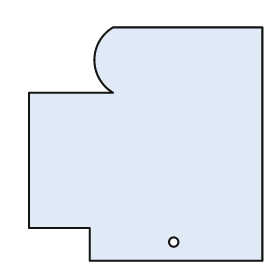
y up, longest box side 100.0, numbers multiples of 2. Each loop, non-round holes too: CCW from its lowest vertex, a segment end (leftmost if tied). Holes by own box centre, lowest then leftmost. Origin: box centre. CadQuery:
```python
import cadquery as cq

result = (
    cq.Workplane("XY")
    .moveTo(-24.0, -50.0)
    .lineTo(50.0, -50.0)
    .lineTo(50.0, 50.0)
    .lineTo(-14.0, 50.0)
    .threePointArc((-22.0, 36.0), (-14.0, 22.0))
    .lineTo(-50.0, 22.0)
    .lineTo(-50.0, -36.0)
    .lineTo(-24.0, -36.0)
    .close()
    .moveTo(12.0, -42.0)
    .circle(2.0)
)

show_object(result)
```